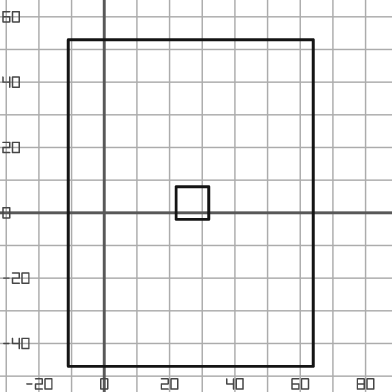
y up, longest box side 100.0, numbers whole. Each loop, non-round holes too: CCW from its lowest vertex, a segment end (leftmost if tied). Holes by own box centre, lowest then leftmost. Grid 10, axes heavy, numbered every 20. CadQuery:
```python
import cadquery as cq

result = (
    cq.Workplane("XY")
    .moveTo(-11.0, -47.0)
    .lineTo(64.0, -47.0)
    .lineTo(64.0, 53.0)
    .lineTo(-11.0, 53.0)
    .close()
    .moveTo(22.0, -2.0)
    .lineTo(32.0, -2.0)
    .lineTo(32.0, 8.0)
    .lineTo(22.0, 8.0)
    .close()
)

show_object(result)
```